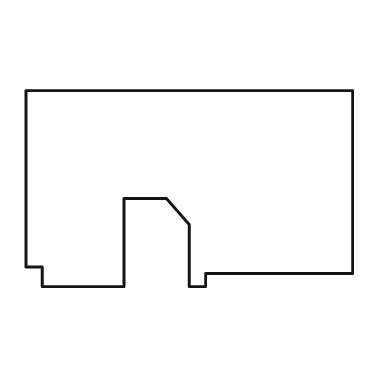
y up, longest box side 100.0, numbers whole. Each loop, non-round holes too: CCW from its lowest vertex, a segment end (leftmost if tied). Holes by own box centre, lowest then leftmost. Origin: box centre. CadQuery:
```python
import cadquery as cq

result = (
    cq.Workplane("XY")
    .moveTo(-45.0, -30.0)
    .lineTo(-20.0, -30.0)
    .lineTo(-20.0, -3.0)
    .lineTo(-7.0, -3.0)
    .lineTo(0.0, -11.0)
    .lineTo(0.0, -30.0)
    .lineTo(5.0, -30.0)
    .lineTo(5.0, -26.0)
    .lineTo(50.0, -26.0)
    .lineTo(50.0, 30.0)
    .lineTo(-50.0, 30.0)
    .lineTo(-50.0, -24.0)
    .lineTo(-45.0, -24.0)
    .close()
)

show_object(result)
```